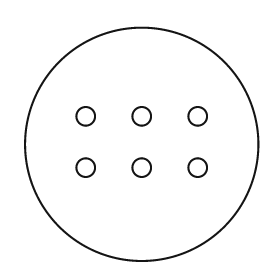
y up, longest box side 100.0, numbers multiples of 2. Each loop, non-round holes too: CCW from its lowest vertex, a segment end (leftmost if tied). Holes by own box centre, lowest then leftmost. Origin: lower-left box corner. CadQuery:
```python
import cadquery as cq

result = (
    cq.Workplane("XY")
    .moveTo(50.0, 50.0)
    .circle(50.0)
    .moveTo(26.0, 40.0)
    .circle(4.0)
    .moveTo(50.0, 40.0)
    .circle(4.0)
    .moveTo(74.0, 40.0)
    .circle(4.0)
    .moveTo(26.0, 62.0)
    .circle(4.0)
    .moveTo(50.0, 62.0)
    .circle(4.0)
    .moveTo(74.0, 62.0)
    .circle(4.0)
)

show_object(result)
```